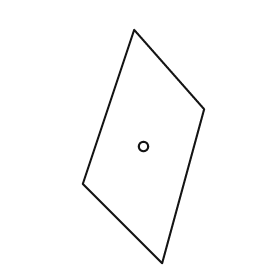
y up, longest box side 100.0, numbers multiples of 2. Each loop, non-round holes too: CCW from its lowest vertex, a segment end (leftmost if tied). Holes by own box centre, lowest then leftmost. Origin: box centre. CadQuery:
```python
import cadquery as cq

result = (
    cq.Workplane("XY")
    .moveTo(8.0, -50.0)
    .lineTo(26.0, 16.0)
    .lineTo(-4.0, 50.0)
    .lineTo(-26.0, -16.0)
    .close()
    .moveTo(0.0, 0.0)
    .circle(2.0)
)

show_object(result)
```